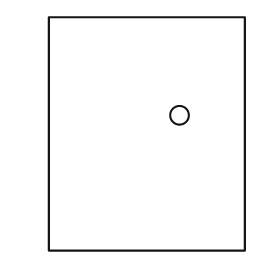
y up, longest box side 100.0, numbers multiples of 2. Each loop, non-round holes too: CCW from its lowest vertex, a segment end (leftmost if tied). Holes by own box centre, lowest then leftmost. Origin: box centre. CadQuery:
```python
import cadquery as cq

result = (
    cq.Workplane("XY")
    .moveTo(-42.0, -50.0)
    .lineTo(42.0, -50.0)
    .lineTo(42.0, 50.0)
    .lineTo(-42.0, 50.0)
    .close()
    .moveTo(14.0, 8.0)
    .circle(4.0)
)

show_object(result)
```